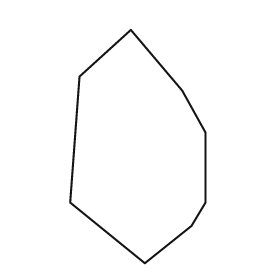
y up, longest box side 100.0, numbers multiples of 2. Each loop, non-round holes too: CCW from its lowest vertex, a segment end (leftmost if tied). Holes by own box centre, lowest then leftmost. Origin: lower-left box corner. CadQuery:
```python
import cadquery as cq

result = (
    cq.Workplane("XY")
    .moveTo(32.0, 0.0)
    .lineTo(52.0, 16.0)
    .lineTo(58.0, 26.0)
    .lineTo(58.0, 56.0)
    .lineTo(48.0, 74.0)
    .lineTo(26.0, 100.0)
    .lineTo(4.0, 80.0)
    .lineTo(0.0, 26.0)
    .close()
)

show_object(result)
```